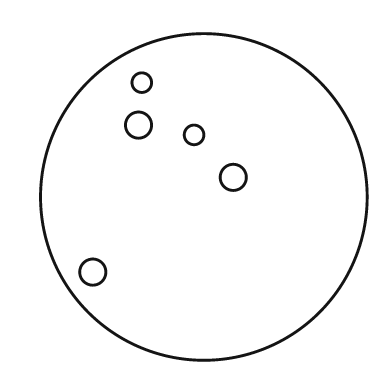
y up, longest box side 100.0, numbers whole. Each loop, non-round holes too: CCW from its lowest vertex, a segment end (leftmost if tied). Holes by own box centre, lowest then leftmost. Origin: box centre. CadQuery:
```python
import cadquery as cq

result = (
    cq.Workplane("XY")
    .moveTo(0.0, 0.0)
    .circle(50.0)
    .moveTo(-34.0, -23.0)
    .circle(4.0)
    .moveTo(9.0, 6.0)
    .circle(4.0)
    .moveTo(-3.0, 19.0)
    .circle(3.0)
    .moveTo(-20.0, 22.0)
    .circle(4.0)
    .moveTo(-19.0, 35.0)
    .circle(3.0)
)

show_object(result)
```